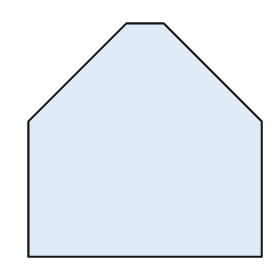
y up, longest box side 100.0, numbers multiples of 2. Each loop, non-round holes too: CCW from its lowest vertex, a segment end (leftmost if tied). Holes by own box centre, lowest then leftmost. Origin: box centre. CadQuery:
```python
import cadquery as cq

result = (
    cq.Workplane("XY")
    .moveTo(-50.0, -50.0)
    .lineTo(50.0, -50.0)
    .lineTo(50.0, 8.0)
    .lineTo(8.0, 50.0)
    .lineTo(-8.0, 50.0)
    .lineTo(-50.0, 8.0)
    .close()
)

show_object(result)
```